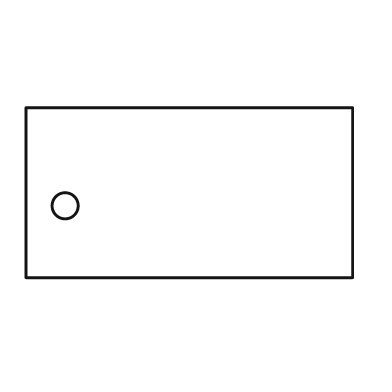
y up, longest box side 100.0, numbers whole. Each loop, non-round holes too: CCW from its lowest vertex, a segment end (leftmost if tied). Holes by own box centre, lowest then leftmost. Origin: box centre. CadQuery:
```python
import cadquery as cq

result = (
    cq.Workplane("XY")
    .moveTo(-50.0, -26.0)
    .lineTo(50.0, -26.0)
    .lineTo(50.0, 26.0)
    .lineTo(-50.0, 26.0)
    .close()
    .moveTo(-38.0, -4.0)
    .circle(4.0)
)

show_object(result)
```